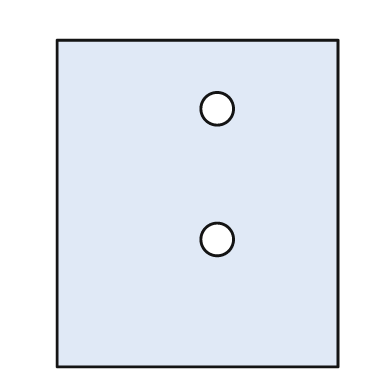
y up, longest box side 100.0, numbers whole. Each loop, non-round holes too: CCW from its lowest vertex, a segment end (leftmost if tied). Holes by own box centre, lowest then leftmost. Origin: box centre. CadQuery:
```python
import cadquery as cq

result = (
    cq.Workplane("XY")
    .moveTo(-43.0, -50.0)
    .lineTo(43.0, -50.0)
    .lineTo(43.0, 50.0)
    .lineTo(-43.0, 50.0)
    .close()
    .moveTo(6.0, -11.0)
    .circle(5.0)
    .moveTo(6.0, 29.0)
    .circle(5.0)
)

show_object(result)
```